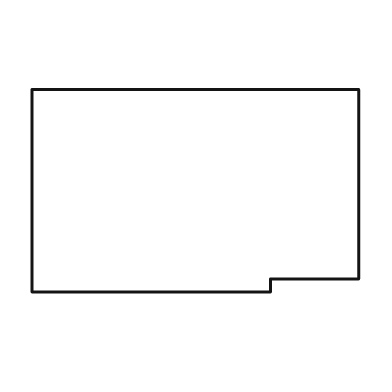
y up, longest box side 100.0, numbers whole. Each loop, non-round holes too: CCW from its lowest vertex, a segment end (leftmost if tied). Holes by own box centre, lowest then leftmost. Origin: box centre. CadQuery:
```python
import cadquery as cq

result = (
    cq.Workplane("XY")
    .moveTo(-50.0, -31.0)
    .lineTo(23.0, -31.0)
    .lineTo(23.0, -27.0)
    .lineTo(50.0, -27.0)
    .lineTo(50.0, 31.0)
    .lineTo(-50.0, 31.0)
    .close()
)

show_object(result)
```